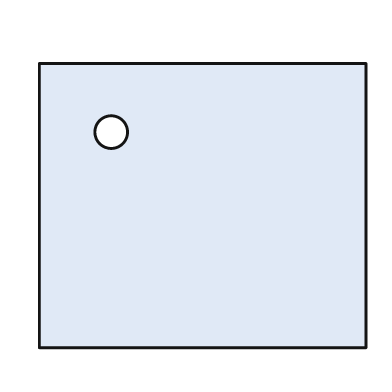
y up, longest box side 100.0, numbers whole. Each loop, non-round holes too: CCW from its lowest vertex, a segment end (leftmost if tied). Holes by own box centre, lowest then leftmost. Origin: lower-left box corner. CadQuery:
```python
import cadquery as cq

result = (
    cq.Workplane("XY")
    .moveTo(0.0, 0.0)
    .lineTo(100.0, 0.0)
    .lineTo(100.0, 87.0)
    .lineTo(0.0, 87.0)
    .close()
    .moveTo(22.0, 66.0)
    .circle(5.0)
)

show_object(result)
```